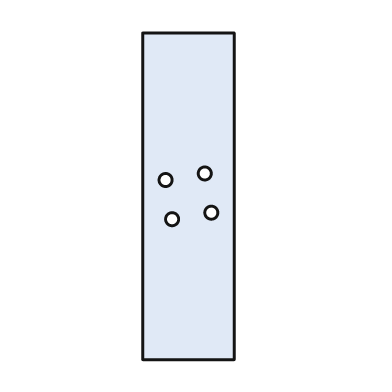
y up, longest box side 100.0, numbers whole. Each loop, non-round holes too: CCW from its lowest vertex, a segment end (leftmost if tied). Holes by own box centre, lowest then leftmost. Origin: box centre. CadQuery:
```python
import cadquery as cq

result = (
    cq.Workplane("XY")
    .moveTo(-14.0, -50.0)
    .lineTo(14.0, -50.0)
    .lineTo(14.0, 50.0)
    .lineTo(-14.0, 50.0)
    .close()
    .moveTo(-5.0, -7.0)
    .circle(2.0)
    .moveTo(7.0, -5.0)
    .circle(2.0)
    .moveTo(-7.0, 5.0)
    .circle(2.0)
    .moveTo(5.0, 7.0)
    .circle(2.0)
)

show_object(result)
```